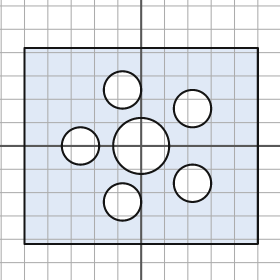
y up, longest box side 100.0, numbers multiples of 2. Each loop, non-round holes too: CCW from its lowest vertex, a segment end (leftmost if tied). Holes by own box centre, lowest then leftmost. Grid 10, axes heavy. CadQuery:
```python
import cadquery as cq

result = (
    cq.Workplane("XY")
    .moveTo(-50.0, -42.0)
    .lineTo(50.0, -42.0)
    .lineTo(50.0, 42.0)
    .lineTo(-50.0, 42.0)
    .close()
    .moveTo(-8.0, -24.0)
    .circle(8.0)
    .moveTo(22.0, -16.0)
    .circle(8.0)
    .moveTo(-26.0, 0.0)
    .circle(8.0)
    .moveTo(0.0, 0.0)
    .circle(12.0)
    .moveTo(22.0, 16.0)
    .circle(8.0)
    .moveTo(-8.0, 24.0)
    .circle(8.0)
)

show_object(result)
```